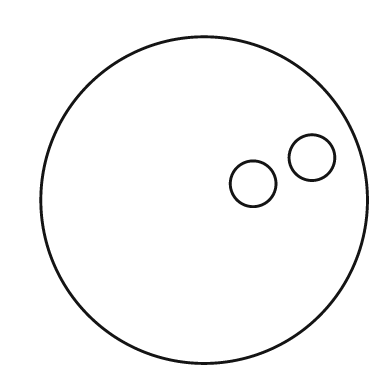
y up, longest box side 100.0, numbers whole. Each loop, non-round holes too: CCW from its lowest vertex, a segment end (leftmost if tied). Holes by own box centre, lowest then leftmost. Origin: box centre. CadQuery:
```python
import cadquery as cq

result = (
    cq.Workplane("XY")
    .moveTo(0.0, 0.0)
    .circle(50.0)
    .moveTo(15.0, 5.0)
    .circle(7.0)
    .moveTo(33.0, 13.0)
    .circle(7.0)
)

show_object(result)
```